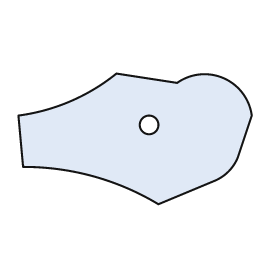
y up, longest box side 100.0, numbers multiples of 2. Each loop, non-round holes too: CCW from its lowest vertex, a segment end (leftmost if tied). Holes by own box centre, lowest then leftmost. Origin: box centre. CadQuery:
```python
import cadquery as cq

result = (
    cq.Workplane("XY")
    .moveTo(10.0, -28.0)
    .lineTo(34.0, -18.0)
    .threePointArc((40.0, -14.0), (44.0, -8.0))
    .lineTo(50.0, 10.0)
    .threePointArc((38.0, 26.0), (18.0, 24.0))
    .lineTo(-8.0, 28.0)
    .threePointArc((-28.0, 16.0), (-50.0, 10.0))
    .lineTo(-48.0, -12.0)
    .threePointArc((-18.0, -16.0), (10.0, -28.0))
    .close()
    .moveTo(6.0, 6.0)
    .circle(4.0)
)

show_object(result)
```